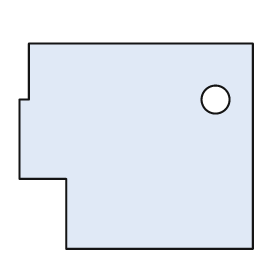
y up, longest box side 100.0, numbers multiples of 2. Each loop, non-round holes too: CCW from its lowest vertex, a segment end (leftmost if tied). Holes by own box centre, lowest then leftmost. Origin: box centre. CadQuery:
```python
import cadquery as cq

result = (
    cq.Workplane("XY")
    .moveTo(-30.0, -44.0)
    .lineTo(50.0, -44.0)
    .lineTo(50.0, 44.0)
    .lineTo(-46.0, 44.0)
    .lineTo(-46.0, 20.0)
    .lineTo(-50.0, 20.0)
    .lineTo(-50.0, -14.0)
    .lineTo(-30.0, -14.0)
    .close()
    .moveTo(34.0, 20.0)
    .circle(6.0)
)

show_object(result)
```